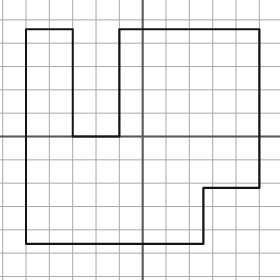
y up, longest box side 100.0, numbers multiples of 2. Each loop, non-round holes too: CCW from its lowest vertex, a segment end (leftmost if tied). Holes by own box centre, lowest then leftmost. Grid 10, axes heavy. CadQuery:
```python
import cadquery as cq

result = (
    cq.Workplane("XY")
    .moveTo(-50.0, -46.0)
    .lineTo(26.0, -46.0)
    .lineTo(26.0, -22.0)
    .lineTo(50.0, -22.0)
    .lineTo(50.0, 46.0)
    .lineTo(-10.0, 46.0)
    .lineTo(-10.0, 0.0)
    .lineTo(-30.0, 0.0)
    .lineTo(-30.0, 46.0)
    .lineTo(-50.0, 46.0)
    .close()
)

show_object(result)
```